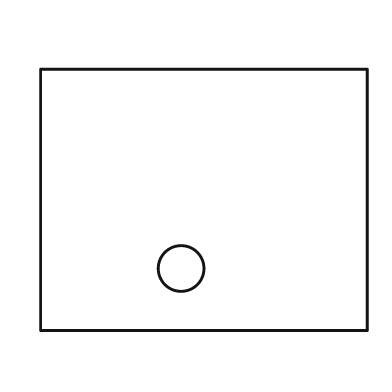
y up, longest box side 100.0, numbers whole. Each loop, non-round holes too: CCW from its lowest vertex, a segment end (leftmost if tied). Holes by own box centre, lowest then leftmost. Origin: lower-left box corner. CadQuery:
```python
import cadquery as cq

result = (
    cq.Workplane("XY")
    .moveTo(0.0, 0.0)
    .lineTo(100.0, 0.0)
    .lineTo(100.0, 80.0)
    .lineTo(0.0, 80.0)
    .close()
    .moveTo(43.0, 19.0)
    .circle(7.0)
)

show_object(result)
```